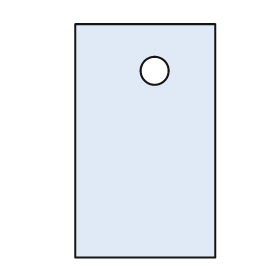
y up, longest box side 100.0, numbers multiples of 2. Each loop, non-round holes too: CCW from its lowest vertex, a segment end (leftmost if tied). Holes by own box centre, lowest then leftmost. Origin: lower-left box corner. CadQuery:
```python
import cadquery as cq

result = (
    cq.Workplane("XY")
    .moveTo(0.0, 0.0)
    .lineTo(60.0, 0.0)
    .lineTo(60.0, 100.0)
    .lineTo(0.0, 100.0)
    .close()
    .moveTo(34.0, 80.0)
    .circle(6.0)
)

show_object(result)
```